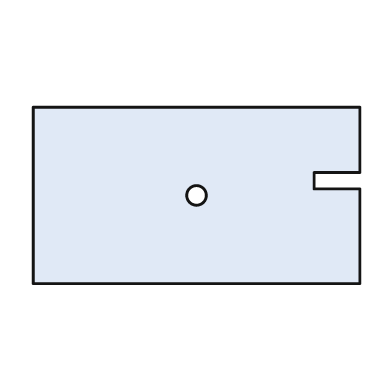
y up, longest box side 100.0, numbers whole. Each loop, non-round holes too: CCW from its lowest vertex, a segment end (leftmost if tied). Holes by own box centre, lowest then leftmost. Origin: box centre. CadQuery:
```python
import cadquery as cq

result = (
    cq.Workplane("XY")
    .moveTo(-50.0, -27.0)
    .lineTo(50.0, -27.0)
    .lineTo(50.0, 2.0)
    .lineTo(36.0, 2.0)
    .lineTo(36.0, 7.0)
    .lineTo(50.0, 7.0)
    .lineTo(50.0, 27.0)
    .lineTo(-50.0, 27.0)
    .close()
    .moveTo(0.0, 0.0)
    .circle(3.0)
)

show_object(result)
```